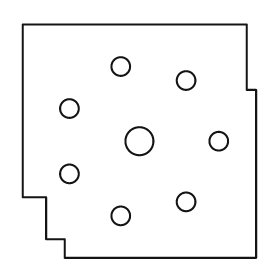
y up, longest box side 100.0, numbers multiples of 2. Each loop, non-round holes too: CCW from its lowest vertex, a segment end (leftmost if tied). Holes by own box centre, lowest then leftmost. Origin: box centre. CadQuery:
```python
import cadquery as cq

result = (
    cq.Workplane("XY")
    .moveTo(-32.0, -50.0)
    .lineTo(50.0, -50.0)
    .lineTo(50.0, 22.0)
    .lineTo(46.0, 22.0)
    .lineTo(46.0, 50.0)
    .lineTo(-50.0, 50.0)
    .lineTo(-50.0, -24.0)
    .lineTo(-40.0, -24.0)
    .lineTo(-40.0, -42.0)
    .lineTo(-32.0, -42.0)
    .close()
    .moveTo(-8.0, -32.0)
    .circle(4.0)
    .moveTo(20.0, -26.0)
    .circle(4.0)
    .moveTo(-30.0, -14.0)
    .circle(4.0)
    .moveTo(0.0, 0.0)
    .circle(6.0)
    .moveTo(34.0, 0.0)
    .circle(4.0)
    .moveTo(-30.0, 14.0)
    .circle(4.0)
    .moveTo(20.0, 26.0)
    .circle(4.0)
    .moveTo(-8.0, 32.0)
    .circle(4.0)
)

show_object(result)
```